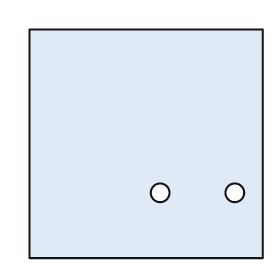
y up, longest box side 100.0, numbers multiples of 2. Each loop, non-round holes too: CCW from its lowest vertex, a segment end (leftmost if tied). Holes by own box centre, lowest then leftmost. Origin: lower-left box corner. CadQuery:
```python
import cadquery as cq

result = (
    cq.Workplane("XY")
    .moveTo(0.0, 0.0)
    .lineTo(100.0, 0.0)
    .lineTo(100.0, 98.0)
    .lineTo(0.0, 98.0)
    .close()
    .moveTo(56.0, 28.0)
    .circle(4.0)
    .moveTo(88.0, 28.0)
    .circle(4.0)
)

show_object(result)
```